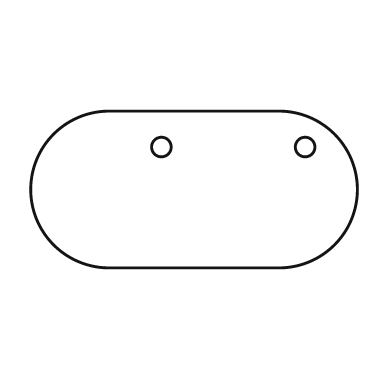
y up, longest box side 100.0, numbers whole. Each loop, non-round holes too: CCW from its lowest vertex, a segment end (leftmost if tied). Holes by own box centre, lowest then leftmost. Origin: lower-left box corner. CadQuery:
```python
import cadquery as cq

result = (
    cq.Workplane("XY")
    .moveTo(24.0, 0.0)
    .lineTo(76.0, 0.0)
    .threePointArc((100.0, 24.0), (76.0, 48.0))
    .lineTo(24.0, 48.0)
    .threePointArc((0.0, 24.0), (24.0, 0.0))
    .close()
    .moveTo(40.0, 37.0)
    .circle(3.0)
    .moveTo(84.0, 37.0)
    .circle(3.0)
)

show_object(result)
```